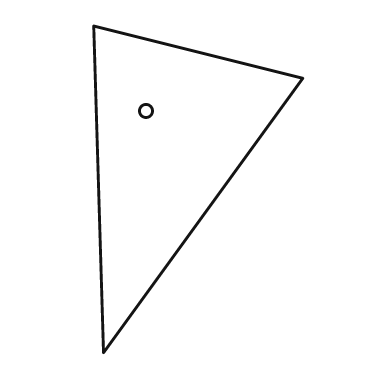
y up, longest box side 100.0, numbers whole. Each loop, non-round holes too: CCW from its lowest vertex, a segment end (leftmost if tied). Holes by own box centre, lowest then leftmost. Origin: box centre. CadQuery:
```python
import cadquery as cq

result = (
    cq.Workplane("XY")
    .moveTo(-29.0, -50.0)
    .lineTo(32.0, 34.0)
    .lineTo(-32.0, 50.0)
    .close()
    .moveTo(-16.0, 24.0)
    .circle(2.0)
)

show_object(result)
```